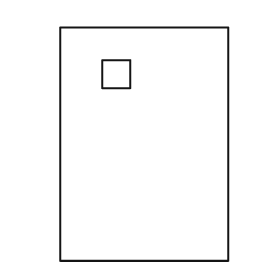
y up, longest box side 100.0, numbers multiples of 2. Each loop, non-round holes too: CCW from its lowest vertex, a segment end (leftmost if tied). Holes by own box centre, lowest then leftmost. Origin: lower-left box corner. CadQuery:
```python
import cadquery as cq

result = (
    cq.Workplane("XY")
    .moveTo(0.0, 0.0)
    .lineTo(72.0, 0.0)
    .lineTo(72.0, 100.0)
    .lineTo(0.0, 100.0)
    .close()
    .moveTo(18.0, 74.0)
    .lineTo(30.0, 74.0)
    .lineTo(30.0, 86.0)
    .lineTo(18.0, 86.0)
    .close()
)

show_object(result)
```